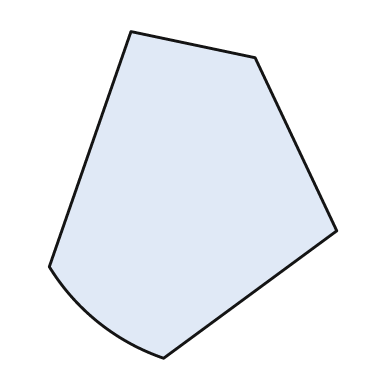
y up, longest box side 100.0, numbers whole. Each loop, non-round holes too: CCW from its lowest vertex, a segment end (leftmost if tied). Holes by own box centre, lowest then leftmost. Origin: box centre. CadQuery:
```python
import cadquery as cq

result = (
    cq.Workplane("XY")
    .moveTo(-9.0, -50.0)
    .lineTo(44.0, -11.0)
    .lineTo(19.0, 42.0)
    .lineTo(-19.0, 50.0)
    .lineTo(-44.0, -22.0)
    .threePointArc((-29.0, -39.0), (-9.0, -50.0))
    .close()
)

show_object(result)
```